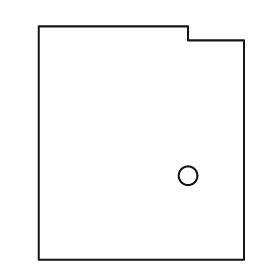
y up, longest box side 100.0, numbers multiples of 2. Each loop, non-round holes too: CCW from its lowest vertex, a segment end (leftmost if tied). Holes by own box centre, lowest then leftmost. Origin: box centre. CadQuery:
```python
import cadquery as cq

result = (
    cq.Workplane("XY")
    .moveTo(-44.0, -50.0)
    .lineTo(44.0, -50.0)
    .lineTo(44.0, 44.0)
    .lineTo(20.0, 44.0)
    .lineTo(20.0, 50.0)
    .lineTo(-44.0, 50.0)
    .close()
    .moveTo(20.0, -14.0)
    .circle(4.0)
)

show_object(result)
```